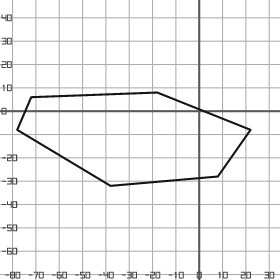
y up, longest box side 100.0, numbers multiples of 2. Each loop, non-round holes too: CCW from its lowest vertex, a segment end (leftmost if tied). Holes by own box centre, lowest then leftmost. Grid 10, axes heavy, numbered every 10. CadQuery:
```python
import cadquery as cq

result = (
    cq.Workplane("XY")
    .moveTo(-38.0, -32.0)
    .lineTo(8.0, -28.0)
    .lineTo(22.0, -8.0)
    .lineTo(-18.0, 8.0)
    .lineTo(-72.0, 6.0)
    .lineTo(-78.0, -8.0)
    .close()
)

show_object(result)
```